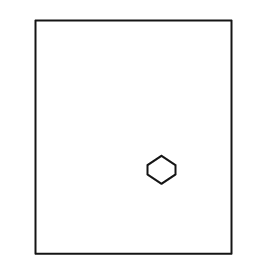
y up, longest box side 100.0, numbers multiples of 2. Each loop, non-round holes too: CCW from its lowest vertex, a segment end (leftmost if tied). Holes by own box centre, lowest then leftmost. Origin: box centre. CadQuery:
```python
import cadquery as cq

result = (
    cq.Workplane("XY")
    .moveTo(-42.0, -50.0)
    .lineTo(42.0, -50.0)
    .lineTo(42.0, 50.0)
    .lineTo(-42.0, 50.0)
    .close()
    .moveTo(12.0, -20.0)
    .lineTo(18.0, -16.0)
    .lineTo(18.0, -12.0)
    .lineTo(12.0, -8.0)
    .lineTo(6.0, -12.0)
    .lineTo(6.0, -16.0)
    .close()
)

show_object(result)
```